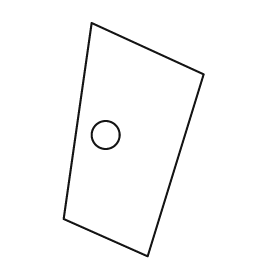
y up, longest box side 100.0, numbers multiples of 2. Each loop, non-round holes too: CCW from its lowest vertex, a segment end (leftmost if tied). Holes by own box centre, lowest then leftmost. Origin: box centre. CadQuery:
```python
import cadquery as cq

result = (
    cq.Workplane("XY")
    .moveTo(6.0, -50.0)
    .lineTo(30.0, 28.0)
    .lineTo(-18.0, 50.0)
    .lineTo(-30.0, -34.0)
    .close()
    .moveTo(-12.0, 2.0)
    .circle(6.0)
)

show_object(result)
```